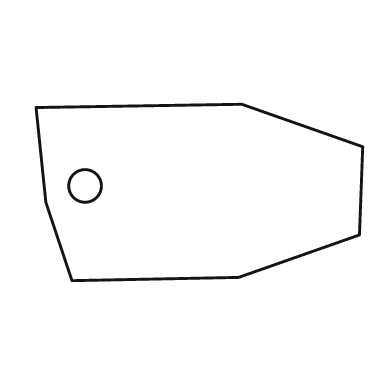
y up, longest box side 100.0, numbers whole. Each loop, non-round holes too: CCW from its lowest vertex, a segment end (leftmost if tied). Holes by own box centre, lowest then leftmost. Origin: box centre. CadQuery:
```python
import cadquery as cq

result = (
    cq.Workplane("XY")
    .moveTo(-39.0, -27.0)
    .lineTo(12.0, -26.0)
    .lineTo(49.0, -13.0)
    .lineTo(50.0, 14.0)
    .lineTo(13.0, 27.0)
    .lineTo(-50.0, 26.0)
    .lineTo(-47.0, -3.0)
    .close()
    .moveTo(-35.0, 2.0)
    .circle(5.0)
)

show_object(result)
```